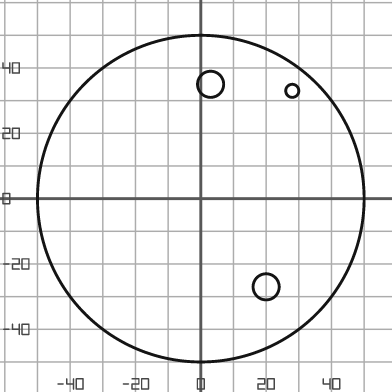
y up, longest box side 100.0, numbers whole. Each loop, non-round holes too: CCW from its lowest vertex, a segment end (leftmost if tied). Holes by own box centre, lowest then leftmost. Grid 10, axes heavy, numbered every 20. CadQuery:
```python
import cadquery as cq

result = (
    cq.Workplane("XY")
    .moveTo(0.0, 0.0)
    .circle(50.0)
    .moveTo(20.0, -27.0)
    .circle(4.0)
    .moveTo(28.0, 33.0)
    .circle(2.0)
    .moveTo(3.0, 35.0)
    .circle(4.0)
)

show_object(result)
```